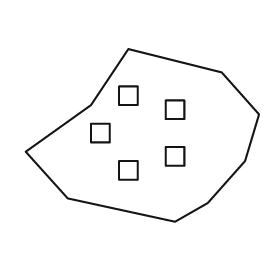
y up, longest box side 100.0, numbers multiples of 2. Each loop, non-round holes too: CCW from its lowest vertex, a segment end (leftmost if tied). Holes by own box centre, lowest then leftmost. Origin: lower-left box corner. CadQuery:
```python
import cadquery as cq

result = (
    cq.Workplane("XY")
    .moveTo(64.0, 0.0)
    .lineTo(78.0, 8.0)
    .lineTo(94.0, 26.0)
    .lineTo(100.0, 46.0)
    .lineTo(84.0, 64.0)
    .lineTo(44.0, 74.0)
    .lineTo(28.0, 50.0)
    .lineTo(0.0, 30.0)
    .lineTo(18.0, 10.0)
    .close()
    .moveTo(40.0, 18.0)
    .lineTo(48.0, 18.0)
    .lineTo(48.0, 26.0)
    .lineTo(40.0, 26.0)
    .close()
    .moveTo(60.0, 24.0)
    .lineTo(68.0, 24.0)
    .lineTo(68.0, 32.0)
    .lineTo(60.0, 32.0)
    .close()
    .moveTo(28.0, 34.0)
    .lineTo(36.0, 34.0)
    .lineTo(36.0, 42.0)
    .lineTo(28.0, 42.0)
    .close()
    .moveTo(60.0, 44.0)
    .lineTo(68.0, 44.0)
    .lineTo(68.0, 52.0)
    .lineTo(60.0, 52.0)
    .close()
    .moveTo(40.0, 50.0)
    .lineTo(48.0, 50.0)
    .lineTo(48.0, 58.0)
    .lineTo(40.0, 58.0)
    .close()
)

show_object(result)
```